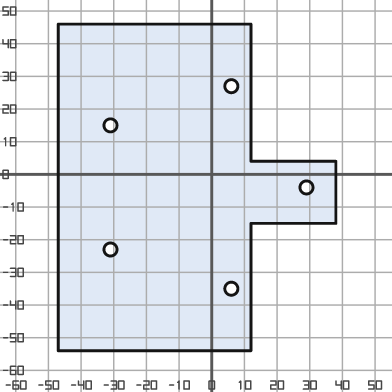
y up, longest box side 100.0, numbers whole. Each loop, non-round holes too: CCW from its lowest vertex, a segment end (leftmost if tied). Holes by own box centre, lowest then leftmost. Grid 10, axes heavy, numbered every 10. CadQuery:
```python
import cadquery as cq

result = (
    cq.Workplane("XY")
    .moveTo(-47.0, -54.0)
    .lineTo(12.0, -54.0)
    .lineTo(12.0, -15.0)
    .lineTo(38.0, -15.0)
    .lineTo(38.0, 4.0)
    .lineTo(12.0, 4.0)
    .lineTo(12.0, 46.0)
    .lineTo(-47.0, 46.0)
    .close()
    .moveTo(6.0, -35.0)
    .circle(2.0)
    .moveTo(-31.0, -23.0)
    .circle(2.0)
    .moveTo(29.0, -4.0)
    .circle(2.0)
    .moveTo(-31.0, 15.0)
    .circle(2.0)
    .moveTo(6.0, 27.0)
    .circle(2.0)
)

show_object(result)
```